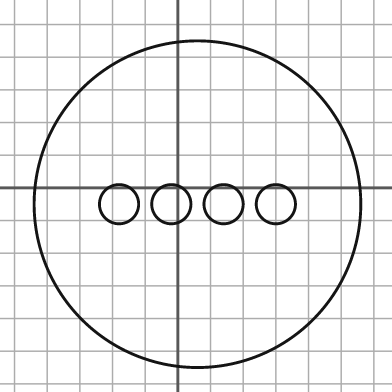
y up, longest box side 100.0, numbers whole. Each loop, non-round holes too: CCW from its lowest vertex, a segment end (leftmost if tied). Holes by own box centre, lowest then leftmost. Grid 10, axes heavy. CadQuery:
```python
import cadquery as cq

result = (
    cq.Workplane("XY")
    .moveTo(6.0, -5.0)
    .circle(50.0)
    .moveTo(-18.0, -5.0)
    .circle(6.0)
    .moveTo(-2.0, -5.0)
    .circle(6.0)
    .moveTo(14.0, -5.0)
    .circle(6.0)
    .moveTo(30.0, -5.0)
    .circle(6.0)
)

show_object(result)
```